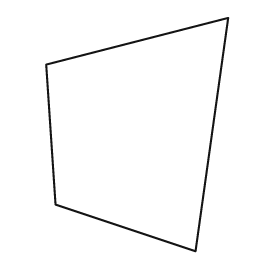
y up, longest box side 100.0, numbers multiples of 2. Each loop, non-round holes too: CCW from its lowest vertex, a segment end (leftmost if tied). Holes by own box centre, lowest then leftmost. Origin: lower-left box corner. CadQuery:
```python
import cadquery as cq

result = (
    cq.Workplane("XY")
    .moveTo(64.0, 0.0)
    .lineTo(78.0, 100.0)
    .lineTo(0.0, 80.0)
    .lineTo(4.0, 20.0)
    .close()
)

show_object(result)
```